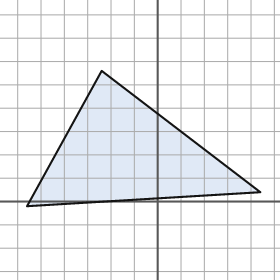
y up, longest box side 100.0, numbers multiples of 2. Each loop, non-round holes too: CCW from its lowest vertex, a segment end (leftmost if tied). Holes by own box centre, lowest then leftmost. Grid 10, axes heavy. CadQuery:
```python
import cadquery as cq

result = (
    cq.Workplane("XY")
    .moveTo(-56.0, -2.0)
    .lineTo(44.0, 4.0)
    .lineTo(-24.0, 56.0)
    .close()
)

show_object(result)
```